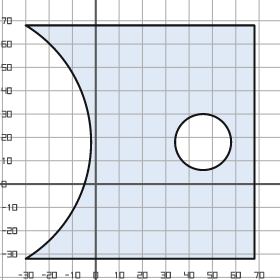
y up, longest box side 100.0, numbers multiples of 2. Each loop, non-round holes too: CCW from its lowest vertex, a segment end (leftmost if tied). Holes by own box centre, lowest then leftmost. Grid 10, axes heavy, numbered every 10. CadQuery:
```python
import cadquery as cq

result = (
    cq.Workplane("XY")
    .moveTo(-30.0, -32.0)
    .lineTo(68.0, -32.0)
    .lineTo(68.0, 68.0)
    .lineTo(-30.0, 68.0)
    .threePointArc((-2.0, 18.0), (-30.0, -32.0))
    .close()
    .moveTo(46.0, 18.0)
    .circle(12.0)
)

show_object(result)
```